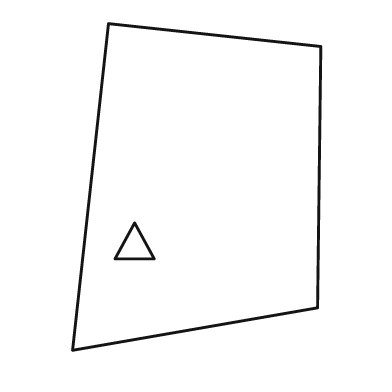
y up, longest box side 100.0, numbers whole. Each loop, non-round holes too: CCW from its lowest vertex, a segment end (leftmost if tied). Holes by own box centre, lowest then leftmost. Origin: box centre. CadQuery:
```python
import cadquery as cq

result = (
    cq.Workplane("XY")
    .moveTo(-38.0, -50.0)
    .lineTo(37.0, -37.0)
    .lineTo(38.0, 43.0)
    .lineTo(-27.0, 50.0)
    .close()
    .moveTo(-25.0, -22.0)
    .lineTo(-13.0, -22.0)
    .lineTo(-19.0, -11.0)
    .close()
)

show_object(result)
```